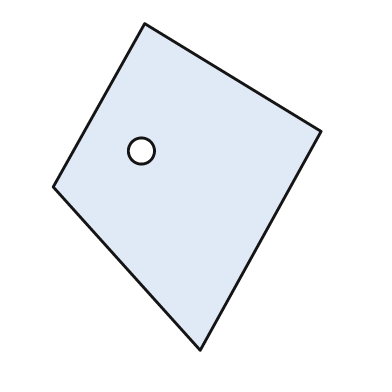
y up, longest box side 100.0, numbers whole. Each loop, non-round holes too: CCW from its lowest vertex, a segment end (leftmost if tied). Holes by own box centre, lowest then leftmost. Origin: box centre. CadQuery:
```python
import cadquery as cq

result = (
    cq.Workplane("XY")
    .moveTo(4.0, -50.0)
    .lineTo(41.0, 17.0)
    .lineTo(-13.0, 50.0)
    .lineTo(-41.0, 0.0)
    .close()
    .moveTo(-14.0, 11.0)
    .circle(4.0)
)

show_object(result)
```